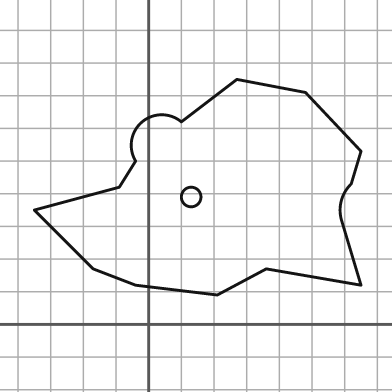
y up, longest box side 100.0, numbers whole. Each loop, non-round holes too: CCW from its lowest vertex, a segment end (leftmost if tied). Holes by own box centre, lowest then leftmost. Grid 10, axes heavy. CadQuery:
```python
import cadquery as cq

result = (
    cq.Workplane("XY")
    .moveTo(21.0, 9.0)
    .lineTo(36.0, 17.0)
    .lineTo(65.0, 12.0)
    .lineTo(59.0, 32.0)
    .threePointArc((59.0, 38.0), (62.0, 43.0))
    .lineTo(65.0, 53.0)
    .lineTo(48.0, 71.0)
    .lineTo(27.0, 75.0)
    .lineTo(10.0, 62.0)
    .threePointArc((-2.0, 62.0), (-4.0, 50.0))
    .lineTo(-9.0, 42.0)
    .lineTo(-35.0, 35.0)
    .lineTo(-17.0, 17.0)
    .lineTo(-4.0, 12.0)
    .close()
    .moveTo(13.0, 39.0)
    .circle(3.0)
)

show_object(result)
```